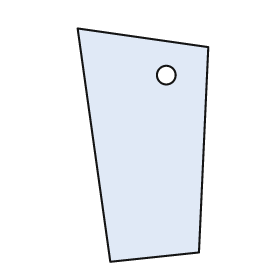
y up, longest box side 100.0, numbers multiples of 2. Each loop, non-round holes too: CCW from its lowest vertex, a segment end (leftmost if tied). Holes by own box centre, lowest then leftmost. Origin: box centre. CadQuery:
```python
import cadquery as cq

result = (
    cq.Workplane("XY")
    .moveTo(-14.0, -50.0)
    .lineTo(24.0, -46.0)
    .lineTo(28.0, 42.0)
    .lineTo(-28.0, 50.0)
    .close()
    .moveTo(10.0, 30.0)
    .circle(4.0)
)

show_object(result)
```